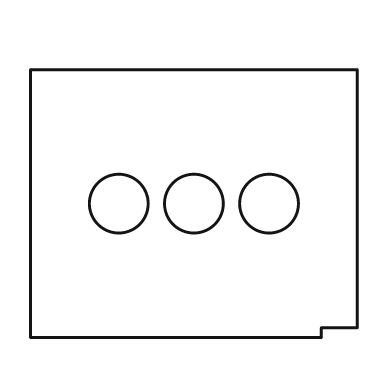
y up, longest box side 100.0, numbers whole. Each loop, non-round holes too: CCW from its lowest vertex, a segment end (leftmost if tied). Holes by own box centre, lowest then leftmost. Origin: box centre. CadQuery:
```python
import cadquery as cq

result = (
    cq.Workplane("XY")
    .moveTo(-50.0, -41.0)
    .lineTo(39.0, -41.0)
    .lineTo(39.0, -38.0)
    .lineTo(50.0, -38.0)
    .lineTo(50.0, 41.0)
    .lineTo(-50.0, 41.0)
    .close()
    .moveTo(-23.0, 0.0)
    .circle(9.0)
    .moveTo(0.0, 0.0)
    .circle(9.0)
    .moveTo(23.0, 0.0)
    .circle(9.0)
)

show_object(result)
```